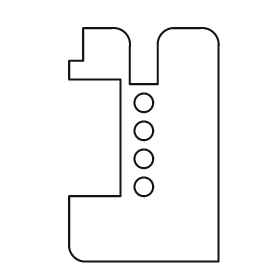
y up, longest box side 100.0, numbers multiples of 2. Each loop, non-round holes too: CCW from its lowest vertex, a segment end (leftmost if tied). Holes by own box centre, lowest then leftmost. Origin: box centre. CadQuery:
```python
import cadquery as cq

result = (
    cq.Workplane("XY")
    .moveTo(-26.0, -50.0)
    .lineTo(32.0, -50.0)
    .lineTo(32.0, 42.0)
    .threePointArc((30.0, 48.0), (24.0, 50.0))
    .lineTo(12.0, 50.0)
    .threePointArc((8.0, 48.0), (6.0, 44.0))
    .lineTo(6.0, 26.0)
    .lineTo(-6.0, 26.0)
    .lineTo(-6.0, 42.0)
    .threePointArc((-8.0, 48.0), (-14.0, 50.0))
    .lineTo(-26.0, 50.0)
    .lineTo(-26.0, 36.0)
    .lineTo(-32.0, 36.0)
    .lineTo(-32.0, 28.0)
    .lineTo(-10.0, 28.0)
    .lineTo(-10.0, -22.0)
    .lineTo(-32.0, -22.0)
    .lineTo(-32.0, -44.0)
    .threePointArc((-30.0, -48.0), (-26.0, -50.0))
    .close()
    .moveTo(0.0, -18.0)
    .circle(4.0)
    .moveTo(0.0, -6.0)
    .circle(4.0)
    .moveTo(0.0, 6.0)
    .circle(4.0)
    .moveTo(0.0, 18.0)
    .circle(4.0)
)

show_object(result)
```